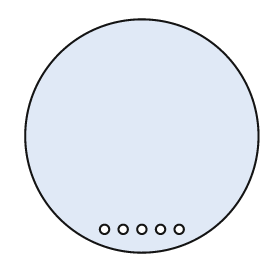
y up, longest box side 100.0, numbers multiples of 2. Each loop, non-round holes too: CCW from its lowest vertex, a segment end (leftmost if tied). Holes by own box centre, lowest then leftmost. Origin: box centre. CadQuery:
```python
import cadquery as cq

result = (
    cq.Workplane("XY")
    .moveTo(0.0, 0.0)
    .circle(50.0)
    .moveTo(-16.0, -40.0)
    .circle(2.0)
    .moveTo(-8.0, -40.0)
    .circle(2.0)
    .moveTo(0.0, -40.0)
    .circle(2.0)
    .moveTo(8.0, -40.0)
    .circle(2.0)
    .moveTo(16.0, -40.0)
    .circle(2.0)
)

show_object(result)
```